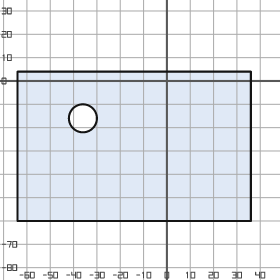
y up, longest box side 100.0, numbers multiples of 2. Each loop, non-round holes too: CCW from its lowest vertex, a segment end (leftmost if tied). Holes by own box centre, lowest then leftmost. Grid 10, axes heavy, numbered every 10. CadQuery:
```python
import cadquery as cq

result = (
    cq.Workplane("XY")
    .moveTo(-64.0, -60.0)
    .lineTo(36.0, -60.0)
    .lineTo(36.0, 4.0)
    .lineTo(-64.0, 4.0)
    .close()
    .moveTo(-36.0, -16.0)
    .circle(6.0)
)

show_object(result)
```